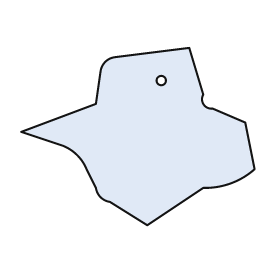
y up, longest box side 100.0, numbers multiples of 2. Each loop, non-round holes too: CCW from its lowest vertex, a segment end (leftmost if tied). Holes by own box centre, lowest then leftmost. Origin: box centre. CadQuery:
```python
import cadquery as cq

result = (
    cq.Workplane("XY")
    .moveTo(4.0, -38.0)
    .lineTo(28.0, -22.0)
    .threePointArc((40.0, -20.0), (50.0, -14.0))
    .lineTo(46.0, 6.0)
    .lineTo(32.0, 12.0)
    .threePointArc((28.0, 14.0), (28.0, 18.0))
    .lineTo(22.0, 38.0)
    .lineTo(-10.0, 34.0)
    .threePointArc((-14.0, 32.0), (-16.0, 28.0))
    .lineTo(-18.0, 14.0)
    .lineTo(-50.0, 2.0)
    .lineTo(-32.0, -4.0)
    .threePointArc((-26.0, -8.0), (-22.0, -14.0))
    .lineTo(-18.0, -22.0)
    .threePointArc((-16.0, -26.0), (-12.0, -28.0))
    .close()
    .moveTo(10.0, 24.0)
    .circle(2.0)
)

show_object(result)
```